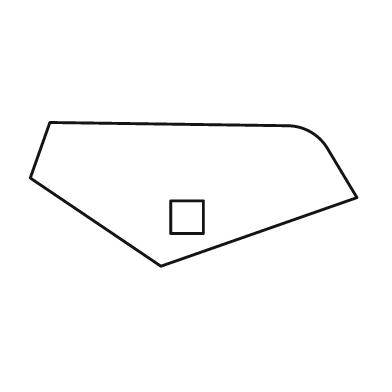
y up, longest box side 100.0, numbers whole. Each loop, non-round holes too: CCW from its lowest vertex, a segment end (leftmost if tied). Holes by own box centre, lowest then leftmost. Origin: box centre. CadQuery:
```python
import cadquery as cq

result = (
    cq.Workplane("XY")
    .moveTo(-10.0, -22.0)
    .lineTo(50.0, -1.0)
    .lineTo(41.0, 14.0)
    .threePointArc((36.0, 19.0), (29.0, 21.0))
    .lineTo(-44.0, 22.0)
    .lineTo(-50.0, 5.0)
    .close()
    .moveTo(-7.0, -12.0)
    .lineTo(3.0, -12.0)
    .lineTo(3.0, -2.0)
    .lineTo(-7.0, -2.0)
    .close()
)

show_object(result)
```